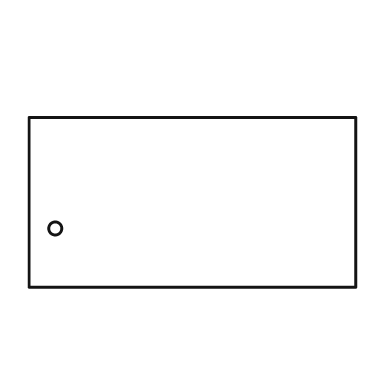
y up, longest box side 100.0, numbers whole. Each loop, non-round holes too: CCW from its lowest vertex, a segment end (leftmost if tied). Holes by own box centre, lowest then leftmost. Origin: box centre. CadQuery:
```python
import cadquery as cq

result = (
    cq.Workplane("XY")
    .moveTo(-50.0, -26.0)
    .lineTo(50.0, -26.0)
    .lineTo(50.0, 26.0)
    .lineTo(-50.0, 26.0)
    .close()
    .moveTo(-42.0, -8.0)
    .circle(2.0)
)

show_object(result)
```